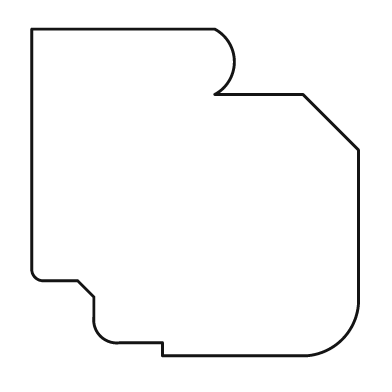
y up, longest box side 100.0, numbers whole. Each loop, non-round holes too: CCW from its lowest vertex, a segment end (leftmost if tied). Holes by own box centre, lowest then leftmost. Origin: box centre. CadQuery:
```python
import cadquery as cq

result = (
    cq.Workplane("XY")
    .moveTo(-10.0, -50.0)
    .lineTo(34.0, -50.0)
    .threePointArc((45.0, -45.0), (50.0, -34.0))
    .lineTo(50.0, 13.0)
    .lineTo(33.0, 30.0)
    .lineTo(6.0, 30.0)
    .threePointArc((12.0, 40.0), (6.0, 50.0))
    .lineTo(-50.0, 50.0)
    .lineTo(-50.0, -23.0)
    .threePointArc((-49.0, -26.0), (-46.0, -27.0))
    .lineTo(-36.0, -27.0)
    .lineTo(-31.0, -32.0)
    .lineTo(-31.0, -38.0)
    .threePointArc((-29.0, -44.0), (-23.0, -46.0))
    .lineTo(-10.0, -46.0)
    .close()
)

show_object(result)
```